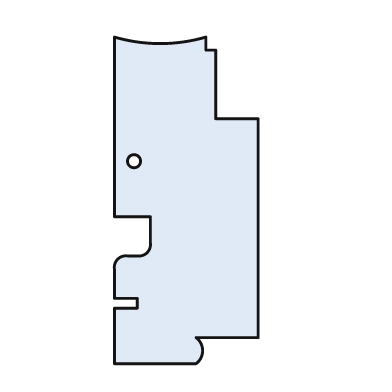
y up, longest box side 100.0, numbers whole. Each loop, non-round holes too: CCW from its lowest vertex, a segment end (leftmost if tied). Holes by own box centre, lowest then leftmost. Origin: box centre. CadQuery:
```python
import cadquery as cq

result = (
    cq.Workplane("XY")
    .moveTo(-22.0, -50.0)
    .lineTo(3.0, -50.0)
    .threePointArc((5.0, -46.0), (3.0, -42.0))
    .lineTo(22.0, -42.0)
    .lineTo(22.0, 25.0)
    .lineTo(9.0, 25.0)
    .lineTo(9.0, 46.0)
    .lineTo(6.0, 46.0)
    .lineTo(6.0, 50.0)
    .threePointArc((-8.0, 48.0), (-22.0, 50.0))
    .lineTo(-22.0, -5.0)
    .lineTo(-11.0, -5.0)
    .lineTo(-11.0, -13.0)
    .threePointArc((-12.0, -16.0), (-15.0, -17.0))
    .lineTo(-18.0, -17.0)
    .threePointArc((-21.0, -18.0), (-22.0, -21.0))
    .lineTo(-22.0, -30.0)
    .lineTo(-15.0, -30.0)
    .lineTo(-15.0, -33.0)
    .lineTo(-22.0, -33.0)
    .close()
    .moveTo(-16.0, 12.0)
    .circle(2.0)
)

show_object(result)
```